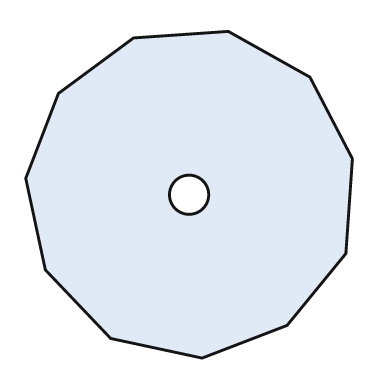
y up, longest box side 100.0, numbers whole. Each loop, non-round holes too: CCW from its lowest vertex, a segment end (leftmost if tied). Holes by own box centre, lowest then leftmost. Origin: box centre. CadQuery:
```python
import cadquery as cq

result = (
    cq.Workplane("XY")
    .moveTo(4.0, -50.0)
    .lineTo(30.0, -40.0)
    .lineTo(48.0, -18.0)
    .lineTo(50.0, 11.0)
    .lineTo(37.0, 36.0)
    .lineTo(12.0, 50.0)
    .lineTo(-17.0, 48.0)
    .lineTo(-40.0, 31.0)
    .lineTo(-50.0, 5.0)
    .lineTo(-44.0, -23.0)
    .lineTo(-24.0, -44.0)
    .close()
    .moveTo(0.0, 0.0)
    .circle(6.0)
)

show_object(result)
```